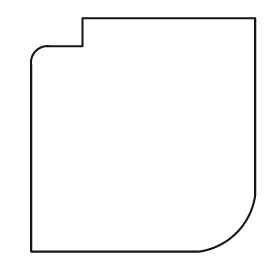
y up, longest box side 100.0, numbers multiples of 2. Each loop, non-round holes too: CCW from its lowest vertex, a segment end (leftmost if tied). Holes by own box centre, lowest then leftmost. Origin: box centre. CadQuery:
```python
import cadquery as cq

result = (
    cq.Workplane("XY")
    .moveTo(-48.0, -50.0)
    .lineTo(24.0, -50.0)
    .threePointArc((40.0, -42.0), (48.0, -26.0))
    .lineTo(48.0, 50.0)
    .lineTo(-26.0, 50.0)
    .lineTo(-26.0, 38.0)
    .lineTo(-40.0, 38.0)
    .threePointArc((-46.0, 36.0), (-48.0, 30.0))
    .close()
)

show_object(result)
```